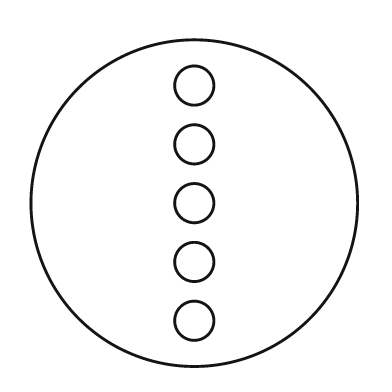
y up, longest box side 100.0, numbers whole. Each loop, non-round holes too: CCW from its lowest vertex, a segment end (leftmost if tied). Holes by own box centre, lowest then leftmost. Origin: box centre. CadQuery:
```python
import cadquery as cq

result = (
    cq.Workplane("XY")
    .moveTo(0.0, 0.0)
    .circle(50.0)
    .moveTo(0.0, -36.0)
    .circle(6.0)
    .moveTo(0.0, -18.0)
    .circle(6.0)
    .moveTo(0.0, 0.0)
    .circle(6.0)
    .moveTo(0.0, 18.0)
    .circle(6.0)
    .moveTo(0.0, 36.0)
    .circle(6.0)
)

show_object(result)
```